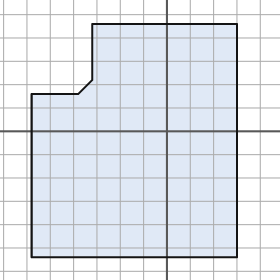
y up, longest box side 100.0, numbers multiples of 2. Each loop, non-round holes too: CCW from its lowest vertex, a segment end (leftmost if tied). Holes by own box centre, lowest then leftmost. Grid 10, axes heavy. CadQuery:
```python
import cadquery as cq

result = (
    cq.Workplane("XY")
    .moveTo(-58.0, -54.0)
    .lineTo(30.0, -54.0)
    .lineTo(30.0, 46.0)
    .lineTo(-32.0, 46.0)
    .lineTo(-32.0, 22.0)
    .lineTo(-38.0, 16.0)
    .lineTo(-58.0, 16.0)
    .close()
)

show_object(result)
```